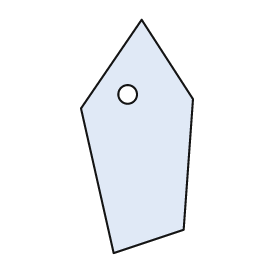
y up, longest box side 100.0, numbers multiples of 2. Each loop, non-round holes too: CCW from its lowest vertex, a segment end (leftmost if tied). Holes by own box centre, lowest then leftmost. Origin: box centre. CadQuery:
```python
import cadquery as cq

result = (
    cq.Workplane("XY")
    .moveTo(-10.0, -50.0)
    .lineTo(20.0, -40.0)
    .lineTo(24.0, 16.0)
    .lineTo(2.0, 50.0)
    .lineTo(-24.0, 12.0)
    .close()
    .moveTo(-4.0, 18.0)
    .circle(4.0)
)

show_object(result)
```